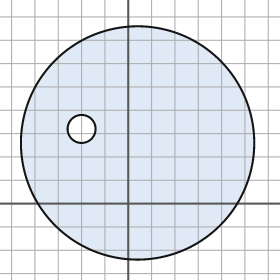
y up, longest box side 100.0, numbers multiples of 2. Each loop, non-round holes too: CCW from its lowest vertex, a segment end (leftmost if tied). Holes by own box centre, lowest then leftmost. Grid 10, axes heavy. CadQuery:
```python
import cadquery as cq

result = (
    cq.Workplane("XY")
    .moveTo(4.0, 26.0)
    .circle(50.0)
    .moveTo(-20.0, 32.0)
    .circle(6.0)
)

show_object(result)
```